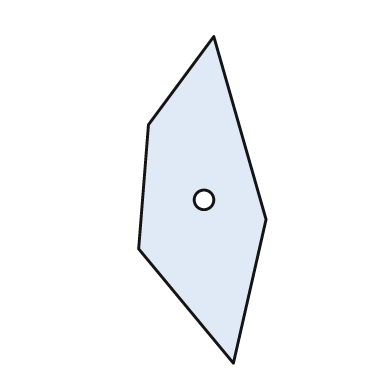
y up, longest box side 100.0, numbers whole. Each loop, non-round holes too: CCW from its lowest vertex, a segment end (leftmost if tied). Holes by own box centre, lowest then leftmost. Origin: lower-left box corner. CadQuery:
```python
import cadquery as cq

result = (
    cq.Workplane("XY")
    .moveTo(29.0, 0.0)
    .lineTo(39.0, 44.0)
    .lineTo(23.0, 100.0)
    .lineTo(3.0, 73.0)
    .lineTo(0.0, 35.0)
    .close()
    .moveTo(20.0, 50.0)
    .circle(3.0)
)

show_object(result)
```